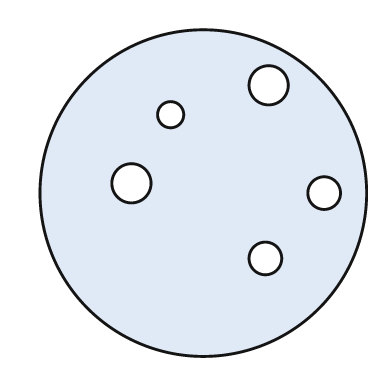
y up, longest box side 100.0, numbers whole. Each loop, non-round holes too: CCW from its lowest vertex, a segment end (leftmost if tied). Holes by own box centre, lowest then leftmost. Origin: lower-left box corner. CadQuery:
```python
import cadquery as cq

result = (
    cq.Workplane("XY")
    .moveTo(50.0, 50.0)
    .circle(50.0)
    .moveTo(69.0, 30.0)
    .circle(5.0)
    .moveTo(87.0, 50.0)
    .circle(5.0)
    .moveTo(28.0, 53.0)
    .circle(6.0)
    .moveTo(40.0, 74.0)
    .circle(4.0)
    .moveTo(70.0, 83.0)
    .circle(6.0)
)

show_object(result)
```